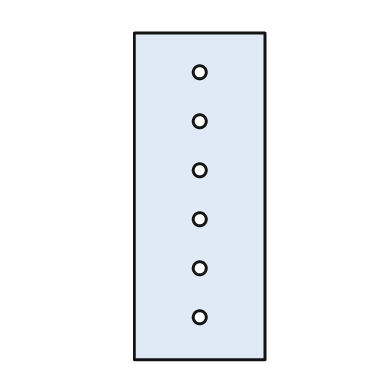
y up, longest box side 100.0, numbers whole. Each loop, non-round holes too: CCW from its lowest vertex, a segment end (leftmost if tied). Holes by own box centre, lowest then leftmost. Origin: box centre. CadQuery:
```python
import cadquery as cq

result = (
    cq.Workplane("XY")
    .moveTo(-20.0, -50.0)
    .lineTo(20.0, -50.0)
    .lineTo(20.0, 50.0)
    .lineTo(-20.0, 50.0)
    .close()
    .moveTo(0.0, -37.0)
    .circle(2.0)
    .moveTo(0.0, -22.0)
    .circle(2.0)
    .moveTo(0.0, -7.0)
    .circle(2.0)
    .moveTo(0.0, 8.0)
    .circle(2.0)
    .moveTo(0.0, 23.0)
    .circle(2.0)
    .moveTo(0.0, 38.0)
    .circle(2.0)
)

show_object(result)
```